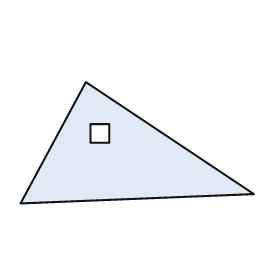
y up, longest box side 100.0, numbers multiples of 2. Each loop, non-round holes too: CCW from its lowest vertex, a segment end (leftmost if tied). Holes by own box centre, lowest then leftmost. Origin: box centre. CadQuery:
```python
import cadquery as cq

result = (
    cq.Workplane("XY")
    .moveTo(-50.0, -26.0)
    .lineTo(50.0, -22.0)
    .lineTo(-22.0, 26.0)
    .close()
    .moveTo(-20.0, 0.0)
    .lineTo(-12.0, 0.0)
    .lineTo(-12.0, 8.0)
    .lineTo(-20.0, 8.0)
    .close()
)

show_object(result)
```